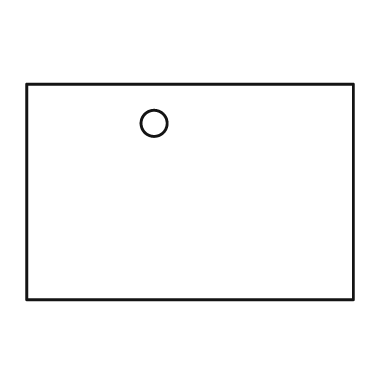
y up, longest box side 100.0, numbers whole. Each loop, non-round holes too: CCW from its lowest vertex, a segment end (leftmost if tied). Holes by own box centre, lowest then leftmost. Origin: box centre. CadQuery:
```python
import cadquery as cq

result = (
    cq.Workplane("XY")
    .moveTo(-50.0, -33.0)
    .lineTo(50.0, -33.0)
    .lineTo(50.0, 33.0)
    .lineTo(-50.0, 33.0)
    .close()
    .moveTo(-11.0, 21.0)
    .circle(4.0)
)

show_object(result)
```